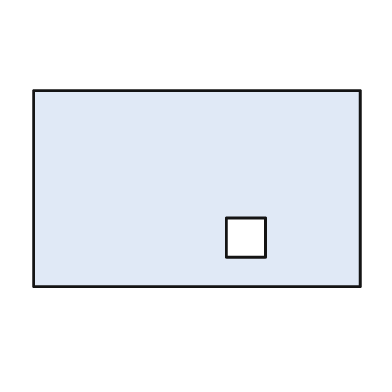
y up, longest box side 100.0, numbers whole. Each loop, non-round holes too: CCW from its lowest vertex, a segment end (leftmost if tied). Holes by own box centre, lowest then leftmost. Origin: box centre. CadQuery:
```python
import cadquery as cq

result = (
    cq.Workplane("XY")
    .moveTo(-50.0, -30.0)
    .lineTo(50.0, -30.0)
    .lineTo(50.0, 30.0)
    .lineTo(-50.0, 30.0)
    .close()
    .moveTo(9.0, -21.0)
    .lineTo(21.0, -21.0)
    .lineTo(21.0, -9.0)
    .lineTo(9.0, -9.0)
    .close()
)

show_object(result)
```